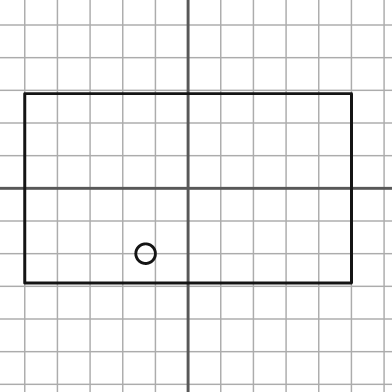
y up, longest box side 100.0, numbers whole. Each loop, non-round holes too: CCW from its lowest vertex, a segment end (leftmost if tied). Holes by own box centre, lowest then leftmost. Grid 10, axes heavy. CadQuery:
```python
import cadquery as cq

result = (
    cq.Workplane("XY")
    .moveTo(-50.0, -29.0)
    .lineTo(50.0, -29.0)
    .lineTo(50.0, 29.0)
    .lineTo(-50.0, 29.0)
    .close()
    .moveTo(-13.0, -20.0)
    .circle(3.0)
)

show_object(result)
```